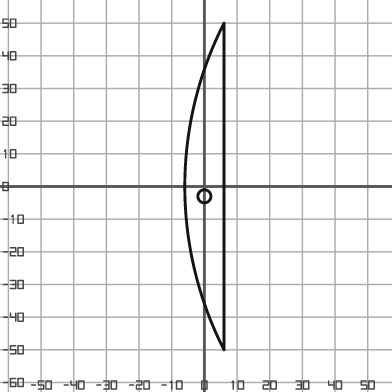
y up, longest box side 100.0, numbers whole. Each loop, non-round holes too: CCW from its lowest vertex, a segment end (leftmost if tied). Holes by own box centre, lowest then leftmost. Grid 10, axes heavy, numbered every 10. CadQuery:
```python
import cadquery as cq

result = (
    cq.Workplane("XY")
    .moveTo(6.0, -50.0)
    .lineTo(6.0, 50.0)
    .threePointArc((-6.0, 0.0), (6.0, -50.0))
    .close()
    .moveTo(0.0, -3.0)
    .circle(2.0)
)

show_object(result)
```